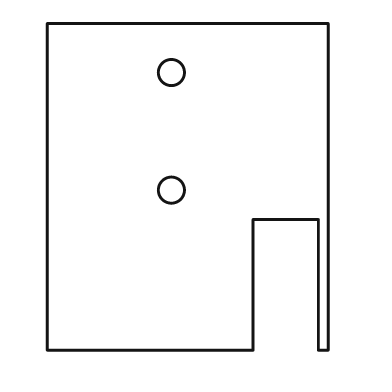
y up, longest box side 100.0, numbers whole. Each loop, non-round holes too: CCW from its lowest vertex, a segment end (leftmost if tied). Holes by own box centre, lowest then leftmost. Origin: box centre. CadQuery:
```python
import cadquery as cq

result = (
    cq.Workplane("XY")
    .moveTo(-43.0, -50.0)
    .lineTo(20.0, -50.0)
    .lineTo(20.0, -10.0)
    .lineTo(40.0, -10.0)
    .lineTo(40.0, -50.0)
    .lineTo(43.0, -50.0)
    .lineTo(43.0, 50.0)
    .lineTo(-43.0, 50.0)
    .close()
    .moveTo(-5.0, -1.0)
    .circle(4.0)
    .moveTo(-5.0, 35.0)
    .circle(4.0)
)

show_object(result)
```